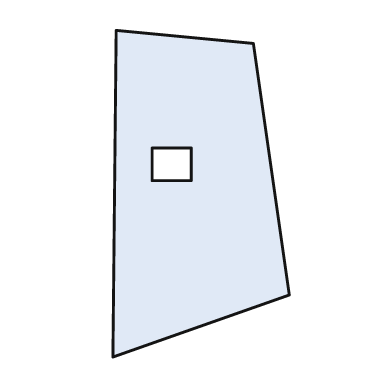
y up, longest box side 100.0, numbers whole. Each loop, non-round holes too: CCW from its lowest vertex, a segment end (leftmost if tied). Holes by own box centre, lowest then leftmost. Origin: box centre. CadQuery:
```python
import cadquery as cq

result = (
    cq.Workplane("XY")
    .moveTo(-27.0, -50.0)
    .lineTo(27.0, -31.0)
    .lineTo(16.0, 46.0)
    .lineTo(-26.0, 50.0)
    .close()
    .moveTo(-15.0, 4.0)
    .lineTo(-3.0, 4.0)
    .lineTo(-3.0, 14.0)
    .lineTo(-15.0, 14.0)
    .close()
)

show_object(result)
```